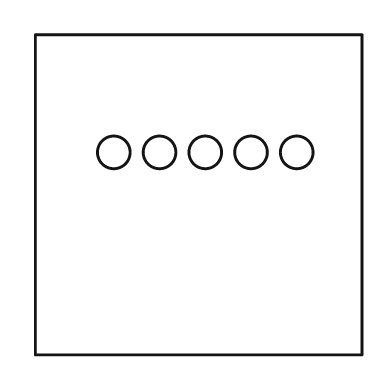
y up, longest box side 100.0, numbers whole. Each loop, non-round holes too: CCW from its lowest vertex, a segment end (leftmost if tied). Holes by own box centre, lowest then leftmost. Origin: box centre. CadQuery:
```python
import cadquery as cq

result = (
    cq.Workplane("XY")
    .moveTo(-50.0, -49.0)
    .lineTo(50.0, -49.0)
    .lineTo(50.0, 49.0)
    .lineTo(-50.0, 49.0)
    .close()
    .moveTo(-26.0, 13.0)
    .circle(5.0)
    .moveTo(-12.0, 13.0)
    .circle(5.0)
    .moveTo(2.0, 13.0)
    .circle(5.0)
    .moveTo(16.0, 13.0)
    .circle(5.0)
    .moveTo(30.0, 13.0)
    .circle(5.0)
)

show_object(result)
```